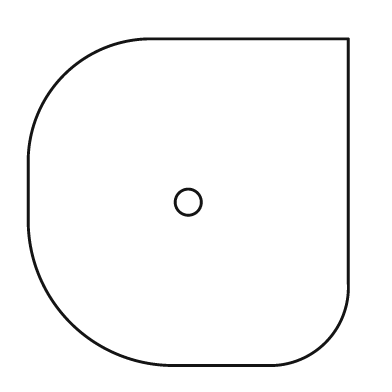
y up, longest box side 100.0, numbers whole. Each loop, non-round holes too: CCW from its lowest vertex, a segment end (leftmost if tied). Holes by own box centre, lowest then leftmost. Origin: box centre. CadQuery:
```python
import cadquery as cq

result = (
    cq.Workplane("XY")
    .moveTo(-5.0, -50.0)
    .lineTo(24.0, -50.0)
    .threePointArc((42.0, -43.0), (49.0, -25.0))
    .lineTo(49.0, 50.0)
    .lineTo(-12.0, 50.0)
    .threePointArc((-38.0, 39.0), (-49.0, 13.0))
    .lineTo(-49.0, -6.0)
    .threePointArc((-36.0, -37.0), (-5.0, -50.0))
    .close()
    .moveTo(0.0, 0.0)
    .circle(4.0)
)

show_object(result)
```